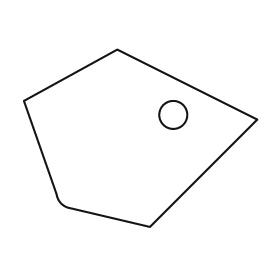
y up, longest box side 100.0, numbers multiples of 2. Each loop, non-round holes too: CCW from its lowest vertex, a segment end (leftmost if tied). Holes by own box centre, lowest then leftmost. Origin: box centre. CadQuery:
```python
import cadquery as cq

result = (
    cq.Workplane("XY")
    .moveTo(4.0, -38.0)
    .lineTo(50.0, 8.0)
    .lineTo(-10.0, 38.0)
    .lineTo(-50.0, 16.0)
    .lineTo(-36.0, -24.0)
    .threePointArc((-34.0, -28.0), (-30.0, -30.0))
    .close()
    .moveTo(14.0, 10.0)
    .circle(6.0)
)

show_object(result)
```